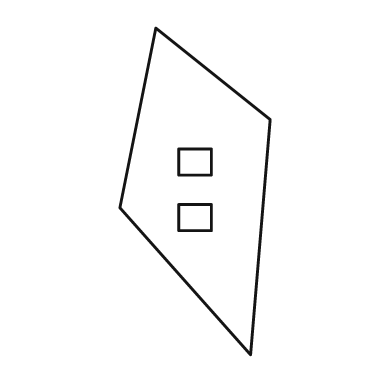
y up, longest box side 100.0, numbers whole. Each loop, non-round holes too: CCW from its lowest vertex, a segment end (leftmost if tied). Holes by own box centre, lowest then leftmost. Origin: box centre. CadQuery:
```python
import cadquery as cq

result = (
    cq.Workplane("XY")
    .moveTo(17.0, -50.0)
    .lineTo(23.0, 22.0)
    .lineTo(-12.0, 50.0)
    .lineTo(-23.0, -5.0)
    .close()
    .moveTo(-5.0, -12.0)
    .lineTo(5.0, -12.0)
    .lineTo(5.0, -4.0)
    .lineTo(-5.0, -4.0)
    .close()
    .moveTo(-5.0, 5.0)
    .lineTo(5.0, 5.0)
    .lineTo(5.0, 13.0)
    .lineTo(-5.0, 13.0)
    .close()
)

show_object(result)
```